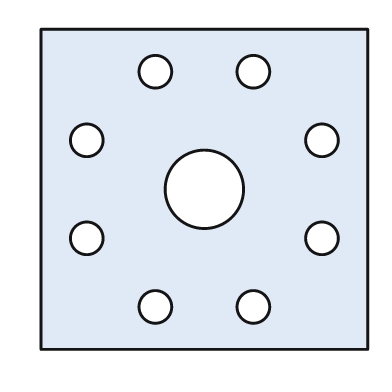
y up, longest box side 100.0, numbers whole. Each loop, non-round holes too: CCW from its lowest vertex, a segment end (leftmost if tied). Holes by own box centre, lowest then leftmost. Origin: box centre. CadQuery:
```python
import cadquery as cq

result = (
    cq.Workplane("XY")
    .moveTo(-50.0, -49.0)
    .lineTo(50.0, -49.0)
    .lineTo(50.0, 49.0)
    .lineTo(-50.0, 49.0)
    .close()
    .moveTo(-15.0, -36.0)
    .circle(5.0)
    .moveTo(15.0, -36.0)
    .circle(5.0)
    .moveTo(-36.0, -15.0)
    .circle(5.0)
    .moveTo(36.0, -15.0)
    .circle(5.0)
    .moveTo(0.0, 0.0)
    .circle(12.0)
    .moveTo(-36.0, 15.0)
    .circle(5.0)
    .moveTo(36.0, 15.0)
    .circle(5.0)
    .moveTo(-15.0, 36.0)
    .circle(5.0)
    .moveTo(15.0, 36.0)
    .circle(5.0)
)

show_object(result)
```